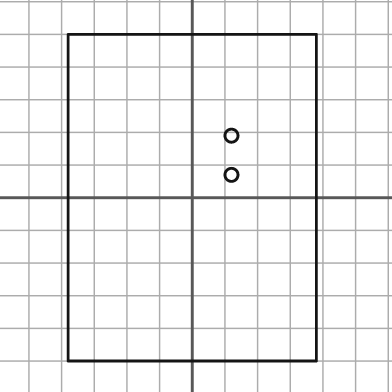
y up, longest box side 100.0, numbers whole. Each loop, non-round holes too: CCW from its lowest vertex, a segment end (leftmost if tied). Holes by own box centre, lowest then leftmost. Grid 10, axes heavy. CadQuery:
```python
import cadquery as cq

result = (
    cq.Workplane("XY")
    .moveTo(-38.0, -50.0)
    .lineTo(38.0, -50.0)
    .lineTo(38.0, 50.0)
    .lineTo(-38.0, 50.0)
    .close()
    .moveTo(12.0, 7.0)
    .circle(2.0)
    .moveTo(12.0, 19.0)
    .circle(2.0)
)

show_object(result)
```